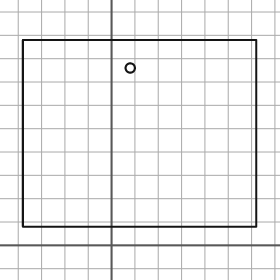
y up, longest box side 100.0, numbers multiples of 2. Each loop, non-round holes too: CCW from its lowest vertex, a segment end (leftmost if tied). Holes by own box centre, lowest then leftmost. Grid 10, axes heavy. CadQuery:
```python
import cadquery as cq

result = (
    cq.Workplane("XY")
    .moveTo(-38.0, 8.0)
    .lineTo(62.0, 8.0)
    .lineTo(62.0, 88.0)
    .lineTo(-38.0, 88.0)
    .close()
    .moveTo(8.0, 76.0)
    .circle(2.0)
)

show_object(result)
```